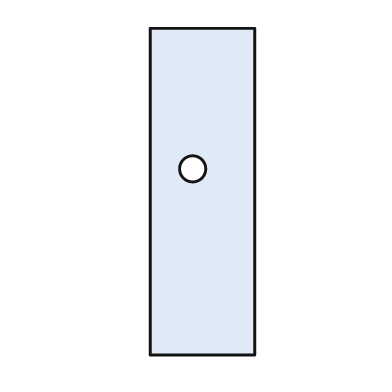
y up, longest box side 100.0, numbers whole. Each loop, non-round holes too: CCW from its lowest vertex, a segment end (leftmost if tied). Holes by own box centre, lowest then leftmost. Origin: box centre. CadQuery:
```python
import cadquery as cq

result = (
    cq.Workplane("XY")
    .moveTo(-16.0, -50.0)
    .lineTo(16.0, -50.0)
    .lineTo(16.0, 50.0)
    .lineTo(-16.0, 50.0)
    .close()
    .moveTo(-3.0, 7.0)
    .circle(4.0)
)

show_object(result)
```